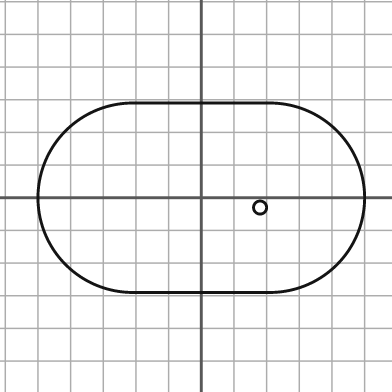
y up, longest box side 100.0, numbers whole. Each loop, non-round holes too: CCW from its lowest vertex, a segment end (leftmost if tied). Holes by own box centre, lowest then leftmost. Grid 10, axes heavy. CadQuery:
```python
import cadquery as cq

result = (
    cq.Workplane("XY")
    .moveTo(-21.0, -29.0)
    .lineTo(21.0, -29.0)
    .threePointArc((50.0, 0.0), (21.0, 29.0))
    .lineTo(-21.0, 29.0)
    .threePointArc((-50.0, 0.0), (-21.0, -29.0))
    .close()
    .moveTo(18.0, -3.0)
    .circle(2.0)
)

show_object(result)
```